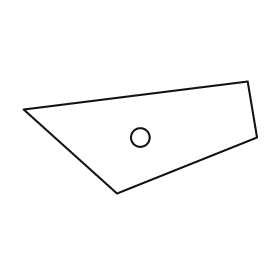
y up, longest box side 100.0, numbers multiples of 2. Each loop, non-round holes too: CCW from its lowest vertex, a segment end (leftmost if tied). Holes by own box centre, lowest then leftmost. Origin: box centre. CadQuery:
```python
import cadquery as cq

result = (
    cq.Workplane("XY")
    .moveTo(-10.0, -24.0)
    .lineTo(50.0, 0.0)
    .lineTo(46.0, 24.0)
    .lineTo(-50.0, 12.0)
    .close()
    .moveTo(0.0, 0.0)
    .circle(4.0)
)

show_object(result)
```